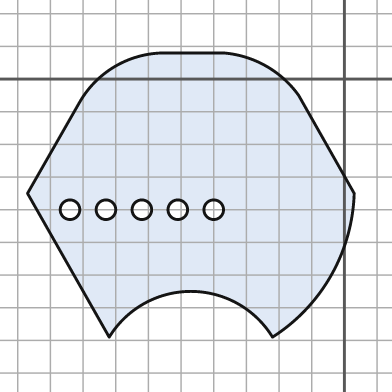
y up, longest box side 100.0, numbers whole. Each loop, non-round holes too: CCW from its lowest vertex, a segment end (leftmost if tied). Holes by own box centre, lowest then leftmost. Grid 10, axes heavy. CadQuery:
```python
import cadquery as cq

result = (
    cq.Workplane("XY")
    .moveTo(-72.0, -79.0)
    .threePointArc((-47.0, -65.0), (-22.0, -79.0))
    .threePointArc((-4.0, -60.0), (3.0, -35.0))
    .lineTo(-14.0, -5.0)
    .threePointArc((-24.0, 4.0), (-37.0, 8.0))
    .lineTo(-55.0, 8.0)
    .threePointArc((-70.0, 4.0), (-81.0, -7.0))
    .lineTo(-97.0, -35.0)
    .close()
    .moveTo(-84.0, -40.0)
    .circle(3.0)
    .moveTo(-73.0, -40.0)
    .circle(3.0)
    .moveTo(-62.0, -40.0)
    .circle(3.0)
    .moveTo(-51.0, -40.0)
    .circle(3.0)
    .moveTo(-40.0, -40.0)
    .circle(3.0)
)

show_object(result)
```